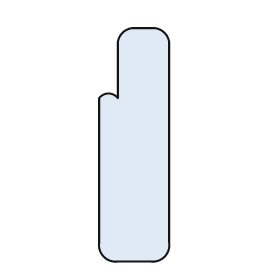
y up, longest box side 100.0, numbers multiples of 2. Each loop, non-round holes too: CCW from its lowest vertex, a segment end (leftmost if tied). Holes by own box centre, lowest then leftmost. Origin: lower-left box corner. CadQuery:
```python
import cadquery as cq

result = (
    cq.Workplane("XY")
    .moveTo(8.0, 0.0)
    .lineTo(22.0, 0.0)
    .threePointArc((28.0, 2.0), (30.0, 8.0))
    .lineTo(30.0, 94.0)
    .threePointArc((28.0, 98.0), (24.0, 100.0))
    .lineTo(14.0, 100.0)
    .threePointArc((10.0, 98.0), (8.0, 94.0))
    .lineTo(8.0, 70.0)
    .threePointArc((4.0, 72.0), (0.0, 70.0))
    .lineTo(0.0, 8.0)
    .threePointArc((2.0, 2.0), (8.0, 0.0))
    .close()
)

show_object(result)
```